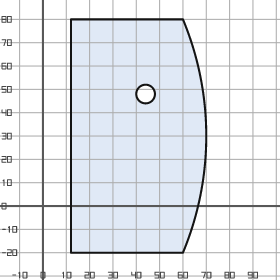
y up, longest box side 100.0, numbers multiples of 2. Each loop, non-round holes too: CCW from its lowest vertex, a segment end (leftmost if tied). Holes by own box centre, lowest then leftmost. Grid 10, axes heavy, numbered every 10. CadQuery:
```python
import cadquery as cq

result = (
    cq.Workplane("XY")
    .moveTo(12.0, -20.0)
    .lineTo(60.0, -20.0)
    .threePointArc((70.0, 30.0), (60.0, 80.0))
    .lineTo(12.0, 80.0)
    .close()
    .moveTo(44.0, 48.0)
    .circle(4.0)
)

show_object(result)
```